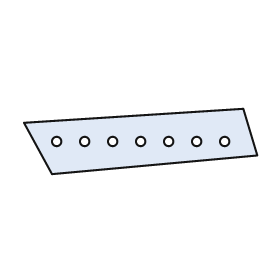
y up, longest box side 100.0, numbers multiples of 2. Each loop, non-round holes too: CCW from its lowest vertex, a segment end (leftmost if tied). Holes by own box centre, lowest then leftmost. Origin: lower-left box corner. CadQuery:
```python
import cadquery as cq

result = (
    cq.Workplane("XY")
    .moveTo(12.0, 0.0)
    .lineTo(100.0, 8.0)
    .lineTo(94.0, 28.0)
    .lineTo(0.0, 22.0)
    .close()
    .moveTo(14.0, 14.0)
    .circle(2.0)
    .moveTo(26.0, 14.0)
    .circle(2.0)
    .moveTo(38.0, 14.0)
    .circle(2.0)
    .moveTo(50.0, 14.0)
    .circle(2.0)
    .moveTo(62.0, 14.0)
    .circle(2.0)
    .moveTo(74.0, 14.0)
    .circle(2.0)
    .moveTo(86.0, 14.0)
    .circle(2.0)
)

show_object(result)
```